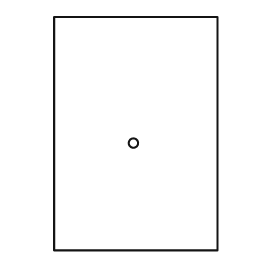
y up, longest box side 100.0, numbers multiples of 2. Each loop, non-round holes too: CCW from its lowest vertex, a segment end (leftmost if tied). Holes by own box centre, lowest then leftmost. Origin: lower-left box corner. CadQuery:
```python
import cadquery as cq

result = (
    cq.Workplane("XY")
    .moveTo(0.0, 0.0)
    .lineTo(70.0, 0.0)
    .lineTo(70.0, 100.0)
    .lineTo(0.0, 100.0)
    .close()
    .moveTo(34.0, 46.0)
    .circle(2.0)
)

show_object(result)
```